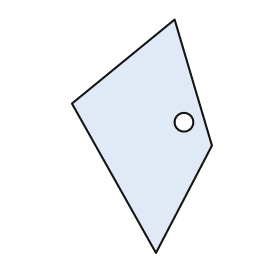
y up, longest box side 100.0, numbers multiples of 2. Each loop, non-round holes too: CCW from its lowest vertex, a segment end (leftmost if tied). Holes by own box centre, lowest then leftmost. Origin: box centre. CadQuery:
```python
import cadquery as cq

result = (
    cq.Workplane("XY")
    .moveTo(6.0, -50.0)
    .lineTo(30.0, -4.0)
    .lineTo(14.0, 50.0)
    .lineTo(-30.0, 14.0)
    .close()
    .moveTo(18.0, 6.0)
    .circle(4.0)
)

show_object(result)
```